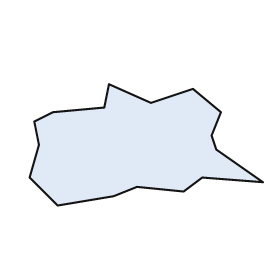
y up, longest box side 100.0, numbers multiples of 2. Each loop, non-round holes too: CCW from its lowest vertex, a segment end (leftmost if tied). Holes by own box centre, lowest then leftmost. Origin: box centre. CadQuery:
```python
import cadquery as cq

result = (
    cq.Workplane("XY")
    .moveTo(-38.0, -26.0)
    .lineTo(-14.0, -22.0)
    .lineTo(-4.0, -18.0)
    .lineTo(16.0, -20.0)
    .lineTo(24.0, -14.0)
    .lineTo(50.0, -16.0)
    .lineTo(30.0, -2.0)
    .lineTo(28.0, 4.0)
    .lineTo(32.0, 14.0)
    .lineTo(20.0, 24.0)
    .lineTo(2.0, 18.0)
    .lineTo(-16.0, 26.0)
    .lineTo(-18.0, 16.0)
    .lineTo(-40.0, 14.0)
    .lineTo(-48.0, 10.0)
    .lineTo(-46.0, 0.0)
    .lineTo(-50.0, -14.0)
    .close()
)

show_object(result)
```